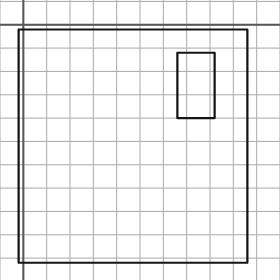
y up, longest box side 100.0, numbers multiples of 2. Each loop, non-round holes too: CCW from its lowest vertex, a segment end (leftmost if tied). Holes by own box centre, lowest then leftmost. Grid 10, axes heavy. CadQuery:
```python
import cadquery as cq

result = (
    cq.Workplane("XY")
    .moveTo(-2.0, -102.0)
    .lineTo(96.0, -102.0)
    .lineTo(96.0, -2.0)
    .lineTo(-2.0, -2.0)
    .close()
    .moveTo(66.0, -40.0)
    .lineTo(82.0, -40.0)
    .lineTo(82.0, -12.0)
    .lineTo(66.0, -12.0)
    .close()
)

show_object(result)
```